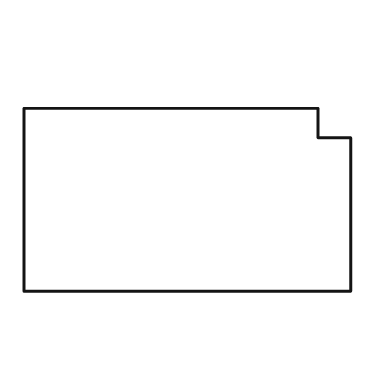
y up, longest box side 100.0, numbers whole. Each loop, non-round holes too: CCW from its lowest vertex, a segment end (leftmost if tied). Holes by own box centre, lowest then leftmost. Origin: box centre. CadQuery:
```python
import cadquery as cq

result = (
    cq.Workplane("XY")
    .moveTo(-50.0, -28.0)
    .lineTo(50.0, -28.0)
    .lineTo(50.0, 19.0)
    .lineTo(40.0, 19.0)
    .lineTo(40.0, 28.0)
    .lineTo(-50.0, 28.0)
    .close()
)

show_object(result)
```